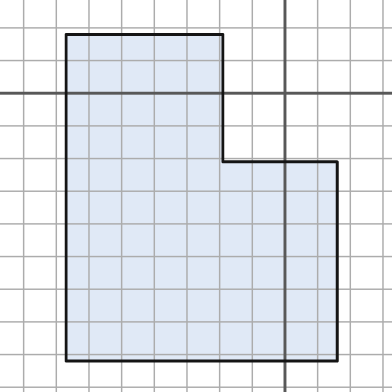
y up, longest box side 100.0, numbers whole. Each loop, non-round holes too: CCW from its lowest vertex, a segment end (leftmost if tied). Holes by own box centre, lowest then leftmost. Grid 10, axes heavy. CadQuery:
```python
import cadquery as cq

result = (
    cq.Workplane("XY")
    .moveTo(-67.0, -82.0)
    .lineTo(16.0, -82.0)
    .lineTo(16.0, -21.0)
    .lineTo(-19.0, -21.0)
    .lineTo(-19.0, 18.0)
    .lineTo(-67.0, 18.0)
    .close()
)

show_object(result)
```